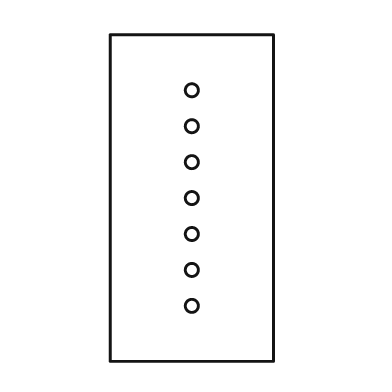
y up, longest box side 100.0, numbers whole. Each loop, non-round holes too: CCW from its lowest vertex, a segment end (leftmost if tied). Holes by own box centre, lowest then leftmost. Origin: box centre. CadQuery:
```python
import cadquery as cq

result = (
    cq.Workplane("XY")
    .moveTo(-25.0, -50.0)
    .lineTo(25.0, -50.0)
    .lineTo(25.0, 50.0)
    .lineTo(-25.0, 50.0)
    .close()
    .moveTo(0.0, -33.0)
    .circle(2.0)
    .moveTo(0.0, -22.0)
    .circle(2.0)
    .moveTo(0.0, -11.0)
    .circle(2.0)
    .moveTo(0.0, 0.0)
    .circle(2.0)
    .moveTo(0.0, 11.0)
    .circle(2.0)
    .moveTo(0.0, 22.0)
    .circle(2.0)
    .moveTo(0.0, 33.0)
    .circle(2.0)
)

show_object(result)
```